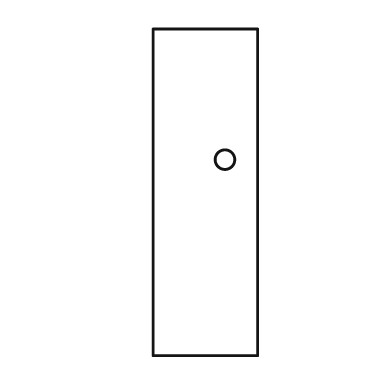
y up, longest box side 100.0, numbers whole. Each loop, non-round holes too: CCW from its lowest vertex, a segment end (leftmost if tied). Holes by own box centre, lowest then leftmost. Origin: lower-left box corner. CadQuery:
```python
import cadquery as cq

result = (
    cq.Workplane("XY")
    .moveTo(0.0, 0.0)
    .lineTo(32.0, 0.0)
    .lineTo(32.0, 100.0)
    .lineTo(0.0, 100.0)
    .close()
    .moveTo(22.0, 60.0)
    .circle(3.0)
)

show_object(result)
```